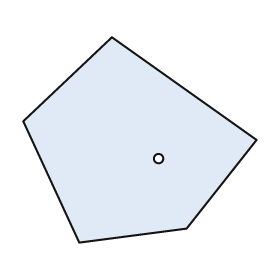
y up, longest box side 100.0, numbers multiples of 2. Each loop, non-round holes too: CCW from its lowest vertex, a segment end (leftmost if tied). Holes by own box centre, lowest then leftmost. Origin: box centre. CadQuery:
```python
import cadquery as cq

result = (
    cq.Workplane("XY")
    .moveTo(-26.0, -44.0)
    .lineTo(20.0, -38.0)
    .lineTo(50.0, 0.0)
    .lineTo(-12.0, 44.0)
    .lineTo(-50.0, 8.0)
    .close()
    .moveTo(8.0, -8.0)
    .circle(2.0)
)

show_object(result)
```